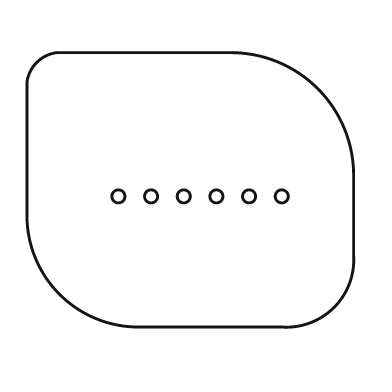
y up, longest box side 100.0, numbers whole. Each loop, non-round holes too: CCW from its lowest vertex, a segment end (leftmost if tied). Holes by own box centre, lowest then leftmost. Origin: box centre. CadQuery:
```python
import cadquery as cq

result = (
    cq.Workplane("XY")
    .moveTo(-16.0, -42.0)
    .lineTo(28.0, -42.0)
    .threePointArc((44.0, -36.0), (50.0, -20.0))
    .lineTo(50.0, 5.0)
    .threePointArc((39.0, 31.0), (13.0, 42.0))
    .lineTo(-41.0, 42.0)
    .threePointArc((-47.0, 39.0), (-50.0, 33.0))
    .lineTo(-50.0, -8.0)
    .threePointArc((-40.0, -32.0), (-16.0, -42.0))
    .close()
    .moveTo(-22.0, -2.0)
    .circle(2.0)
    .moveTo(-12.0, -2.0)
    .circle(2.0)
    .moveTo(-2.0, -2.0)
    .circle(2.0)
    .moveTo(8.0, -2.0)
    .circle(2.0)
    .moveTo(18.0, -2.0)
    .circle(2.0)
    .moveTo(28.0, -2.0)
    .circle(2.0)
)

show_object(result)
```